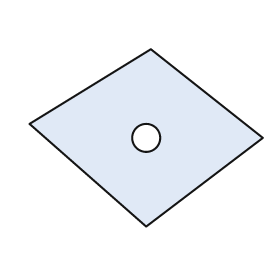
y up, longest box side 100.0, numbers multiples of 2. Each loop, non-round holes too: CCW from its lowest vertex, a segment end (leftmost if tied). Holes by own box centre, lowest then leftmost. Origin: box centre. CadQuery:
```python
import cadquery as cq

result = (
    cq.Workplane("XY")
    .moveTo(0.0, -38.0)
    .lineTo(50.0, 0.0)
    .lineTo(2.0, 38.0)
    .lineTo(-50.0, 6.0)
    .close()
    .moveTo(0.0, 0.0)
    .circle(6.0)
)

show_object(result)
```